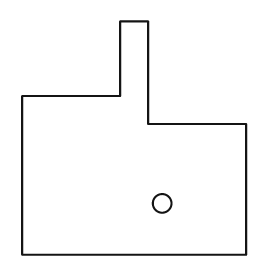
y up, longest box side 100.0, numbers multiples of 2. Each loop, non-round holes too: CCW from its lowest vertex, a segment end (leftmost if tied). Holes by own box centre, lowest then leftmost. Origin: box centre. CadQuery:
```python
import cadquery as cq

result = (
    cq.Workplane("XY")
    .moveTo(-48.0, -50.0)
    .lineTo(48.0, -50.0)
    .lineTo(48.0, 6.0)
    .lineTo(6.0, 6.0)
    .lineTo(6.0, 50.0)
    .lineTo(-6.0, 50.0)
    .lineTo(-6.0, 18.0)
    .lineTo(-48.0, 18.0)
    .close()
    .moveTo(12.0, -28.0)
    .circle(4.0)
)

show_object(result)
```